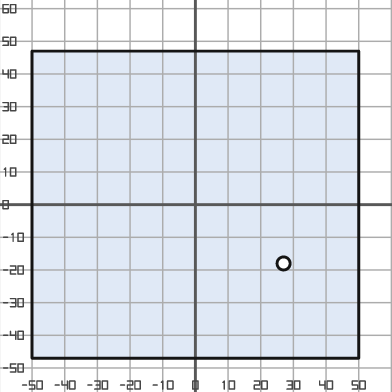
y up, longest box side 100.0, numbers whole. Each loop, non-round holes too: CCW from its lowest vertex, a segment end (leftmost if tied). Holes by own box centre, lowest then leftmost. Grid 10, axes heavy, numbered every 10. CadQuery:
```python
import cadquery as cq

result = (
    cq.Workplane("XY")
    .moveTo(-50.0, -47.0)
    .lineTo(50.0, -47.0)
    .lineTo(50.0, 47.0)
    .lineTo(-50.0, 47.0)
    .close()
    .moveTo(27.0, -18.0)
    .circle(2.0)
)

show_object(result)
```